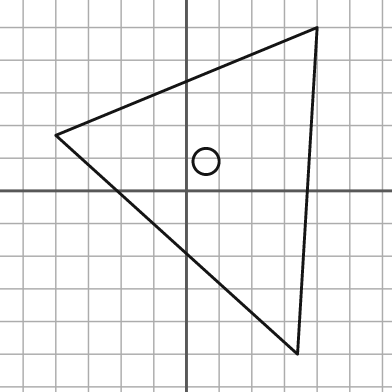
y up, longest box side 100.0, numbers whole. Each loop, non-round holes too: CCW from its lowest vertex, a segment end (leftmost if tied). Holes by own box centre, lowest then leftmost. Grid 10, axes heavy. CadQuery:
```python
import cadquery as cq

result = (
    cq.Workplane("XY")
    .moveTo(34.0, -50.0)
    .lineTo(40.0, 50.0)
    .lineTo(-40.0, 17.0)
    .close()
    .moveTo(6.0, 9.0)
    .circle(4.0)
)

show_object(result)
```